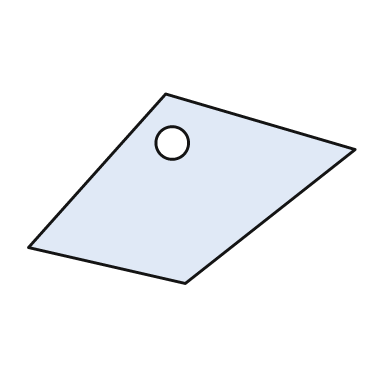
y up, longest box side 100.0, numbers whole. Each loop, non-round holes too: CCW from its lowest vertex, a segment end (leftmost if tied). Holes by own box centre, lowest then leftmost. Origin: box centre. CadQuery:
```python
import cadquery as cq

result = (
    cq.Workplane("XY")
    .moveTo(-2.0, -29.0)
    .lineTo(50.0, 12.0)
    .lineTo(-8.0, 29.0)
    .lineTo(-50.0, -18.0)
    .close()
    .moveTo(-6.0, 14.0)
    .circle(5.0)
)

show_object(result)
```